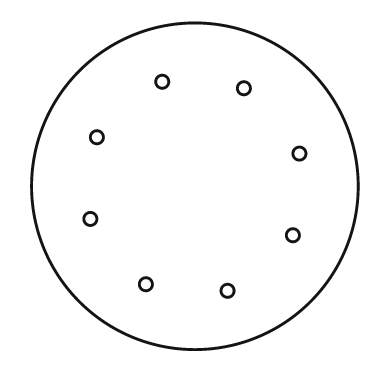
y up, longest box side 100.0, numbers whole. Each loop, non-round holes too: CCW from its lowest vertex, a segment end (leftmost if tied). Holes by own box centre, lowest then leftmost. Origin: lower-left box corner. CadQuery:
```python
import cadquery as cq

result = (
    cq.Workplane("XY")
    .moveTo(50.0, 50.0)
    .circle(50.0)
    .moveTo(60.0, 18.0)
    .circle(2.0)
    .moveTo(35.0, 20.0)
    .circle(2.0)
    .moveTo(80.0, 35.0)
    .circle(2.0)
    .moveTo(18.0, 40.0)
    .circle(2.0)
    .moveTo(82.0, 60.0)
    .circle(2.0)
    .moveTo(20.0, 65.0)
    .circle(2.0)
    .moveTo(65.0, 80.0)
    .circle(2.0)
    .moveTo(40.0, 82.0)
    .circle(2.0)
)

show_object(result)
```